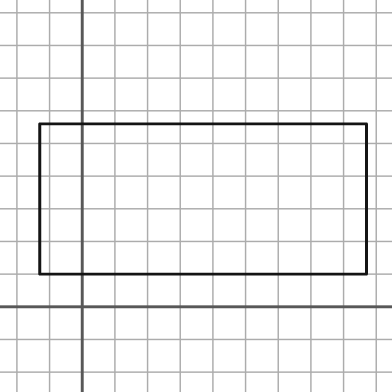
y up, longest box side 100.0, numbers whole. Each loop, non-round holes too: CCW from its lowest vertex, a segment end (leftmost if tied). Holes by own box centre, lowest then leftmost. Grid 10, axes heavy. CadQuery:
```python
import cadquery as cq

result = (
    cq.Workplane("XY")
    .moveTo(-13.0, 10.0)
    .lineTo(87.0, 10.0)
    .lineTo(87.0, 56.0)
    .lineTo(-13.0, 56.0)
    .close()
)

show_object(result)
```